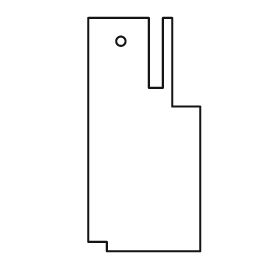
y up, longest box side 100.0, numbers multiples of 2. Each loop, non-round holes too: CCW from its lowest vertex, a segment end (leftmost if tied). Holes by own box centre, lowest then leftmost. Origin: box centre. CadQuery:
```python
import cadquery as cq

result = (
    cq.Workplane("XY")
    .moveTo(-16.0, -50.0)
    .lineTo(24.0, -50.0)
    .lineTo(24.0, 12.0)
    .lineTo(12.0, 12.0)
    .lineTo(12.0, 50.0)
    .lineTo(8.0, 50.0)
    .lineTo(8.0, 20.0)
    .lineTo(2.0, 20.0)
    .lineTo(2.0, 50.0)
    .lineTo(-24.0, 50.0)
    .lineTo(-24.0, -46.0)
    .lineTo(-16.0, -46.0)
    .close()
    .moveTo(-10.0, 40.0)
    .circle(2.0)
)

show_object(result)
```